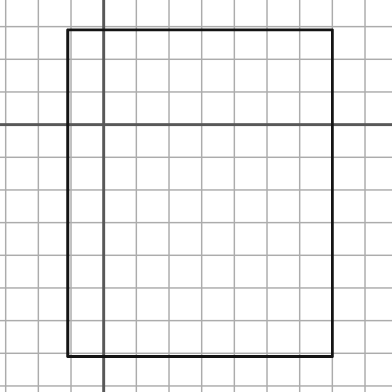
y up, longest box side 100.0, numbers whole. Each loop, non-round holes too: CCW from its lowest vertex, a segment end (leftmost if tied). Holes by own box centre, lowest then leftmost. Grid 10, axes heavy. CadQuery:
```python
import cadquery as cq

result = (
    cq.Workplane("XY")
    .moveTo(-11.0, -71.0)
    .lineTo(70.0, -71.0)
    .lineTo(70.0, 29.0)
    .lineTo(-11.0, 29.0)
    .close()
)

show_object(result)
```